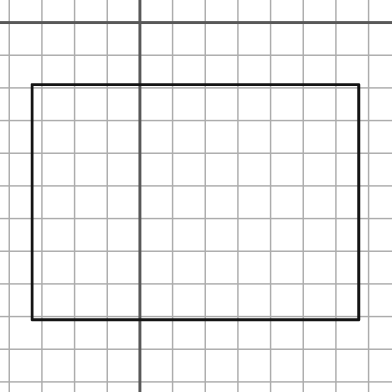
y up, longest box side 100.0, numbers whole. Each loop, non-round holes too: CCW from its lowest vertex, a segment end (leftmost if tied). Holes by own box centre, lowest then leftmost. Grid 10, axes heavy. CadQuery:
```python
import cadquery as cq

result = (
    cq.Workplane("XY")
    .moveTo(-33.0, -91.0)
    .lineTo(67.0, -91.0)
    .lineTo(67.0, -19.0)
    .lineTo(-33.0, -19.0)
    .close()
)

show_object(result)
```